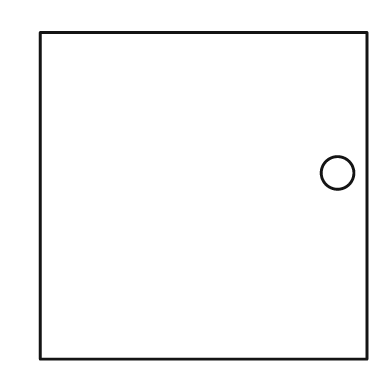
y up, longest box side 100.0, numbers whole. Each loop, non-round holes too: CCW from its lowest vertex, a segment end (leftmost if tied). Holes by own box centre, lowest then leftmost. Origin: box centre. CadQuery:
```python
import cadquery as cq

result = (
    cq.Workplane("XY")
    .moveTo(-50.0, -50.0)
    .lineTo(50.0, -50.0)
    .lineTo(50.0, 50.0)
    .lineTo(-50.0, 50.0)
    .close()
    .moveTo(41.0, 7.0)
    .circle(5.0)
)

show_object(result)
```